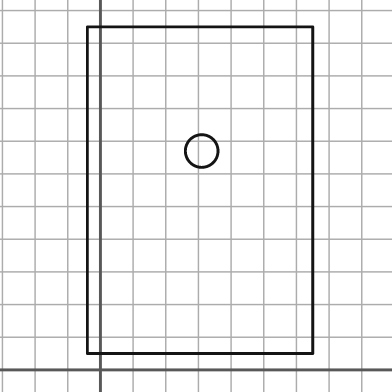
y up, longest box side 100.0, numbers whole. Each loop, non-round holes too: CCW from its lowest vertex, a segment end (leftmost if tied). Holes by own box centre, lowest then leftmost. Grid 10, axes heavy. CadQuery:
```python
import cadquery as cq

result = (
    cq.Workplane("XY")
    .moveTo(-4.0, 5.0)
    .lineTo(65.0, 5.0)
    .lineTo(65.0, 105.0)
    .lineTo(-4.0, 105.0)
    .close()
    .moveTo(31.0, 67.0)
    .circle(5.0)
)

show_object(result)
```